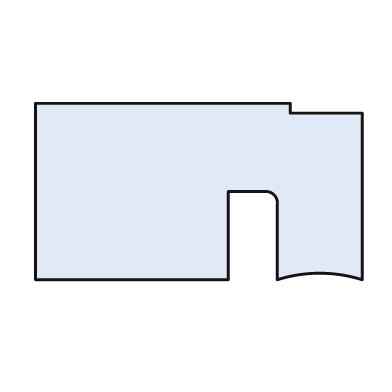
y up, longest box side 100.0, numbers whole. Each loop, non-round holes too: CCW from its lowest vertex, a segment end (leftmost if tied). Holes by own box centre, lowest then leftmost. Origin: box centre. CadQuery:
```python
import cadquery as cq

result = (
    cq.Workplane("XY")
    .moveTo(-50.0, -27.0)
    .lineTo(9.0, -27.0)
    .lineTo(9.0, 0.0)
    .lineTo(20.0, 0.0)
    .threePointArc((23.0, -1.0), (24.0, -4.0))
    .lineTo(24.0, -27.0)
    .threePointArc((37.0, -25.0), (50.0, -27.0))
    .lineTo(50.0, 24.0)
    .lineTo(28.0, 24.0)
    .lineTo(28.0, 27.0)
    .lineTo(-50.0, 27.0)
    .close()
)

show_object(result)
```